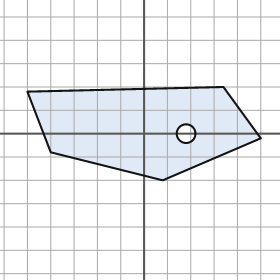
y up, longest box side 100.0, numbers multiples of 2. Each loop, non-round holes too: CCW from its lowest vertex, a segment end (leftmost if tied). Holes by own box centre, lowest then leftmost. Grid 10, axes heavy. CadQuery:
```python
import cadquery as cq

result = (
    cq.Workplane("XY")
    .moveTo(8.0, -20.0)
    .lineTo(50.0, -2.0)
    .lineTo(34.0, 20.0)
    .lineTo(-50.0, 18.0)
    .lineTo(-40.0, -8.0)
    .close()
    .moveTo(18.0, 0.0)
    .circle(4.0)
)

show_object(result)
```